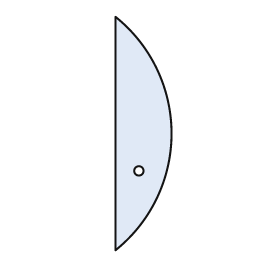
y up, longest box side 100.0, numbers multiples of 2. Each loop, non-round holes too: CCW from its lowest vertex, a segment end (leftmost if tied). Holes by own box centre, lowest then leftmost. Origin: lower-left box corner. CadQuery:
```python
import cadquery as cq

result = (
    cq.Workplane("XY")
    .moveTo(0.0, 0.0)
    .threePointArc((24.0, 50.0), (0.0, 100.0))
    .close()
    .moveTo(10.0, 34.0)
    .circle(2.0)
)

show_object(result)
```